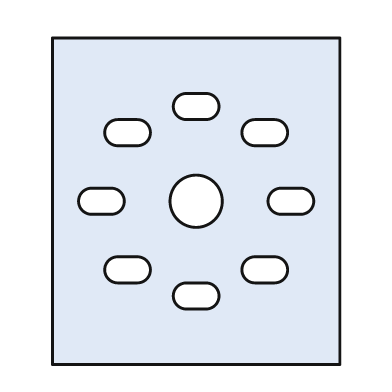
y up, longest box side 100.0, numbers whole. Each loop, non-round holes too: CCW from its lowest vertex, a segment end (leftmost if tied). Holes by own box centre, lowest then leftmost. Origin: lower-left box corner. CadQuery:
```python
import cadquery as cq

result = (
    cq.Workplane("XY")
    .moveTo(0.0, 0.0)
    .lineTo(88.0, 0.0)
    .lineTo(88.0, 100.0)
    .lineTo(0.0, 100.0)
    .close()
    .moveTo(41.0, 17.0)
    .lineTo(47.0, 17.0)
    .threePointArc((51.0, 21.0), (47.0, 25.0))
    .lineTo(41.0, 25.0)
    .threePointArc((37.0, 21.0), (41.0, 17.0))
    .close()
    .moveTo(20.0, 25.0)
    .lineTo(26.0, 25.0)
    .threePointArc((30.0, 29.0), (26.0, 33.0))
    .lineTo(20.0, 33.0)
    .threePointArc((16.0, 29.0), (20.0, 25.0))
    .close()
    .moveTo(62.0, 25.0)
    .lineTo(68.0, 25.0)
    .threePointArc((72.0, 29.0), (68.0, 33.0))
    .lineTo(62.0, 33.0)
    .threePointArc((58.0, 29.0), (62.0, 25.0))
    .close()
    .moveTo(12.0, 46.0)
    .lineTo(18.0, 46.0)
    .threePointArc((22.0, 50.0), (18.0, 54.0))
    .lineTo(12.0, 54.0)
    .threePointArc((8.0, 50.0), (12.0, 46.0))
    .close()
    .moveTo(44.0, 50.0)
    .circle(8.0)
    .moveTo(70.0, 46.0)
    .lineTo(76.0, 46.0)
    .threePointArc((80.0, 50.0), (76.0, 54.0))
    .lineTo(70.0, 54.0)
    .threePointArc((66.0, 50.0), (70.0, 46.0))
    .close()
    .moveTo(20.0, 67.0)
    .lineTo(26.0, 67.0)
    .threePointArc((30.0, 71.0), (26.0, 75.0))
    .lineTo(20.0, 75.0)
    .threePointArc((16.0, 71.0), (20.0, 67.0))
    .close()
    .moveTo(62.0, 67.0)
    .lineTo(68.0, 67.0)
    .threePointArc((72.0, 71.0), (68.0, 75.0))
    .lineTo(62.0, 75.0)
    .threePointArc((58.0, 71.0), (62.0, 67.0))
    .close()
    .moveTo(41.0, 75.0)
    .lineTo(47.0, 75.0)
    .threePointArc((51.0, 79.0), (47.0, 83.0))
    .lineTo(41.0, 83.0)
    .threePointArc((37.0, 79.0), (41.0, 75.0))
    .close()
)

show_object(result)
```